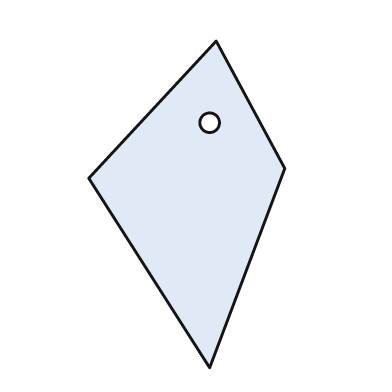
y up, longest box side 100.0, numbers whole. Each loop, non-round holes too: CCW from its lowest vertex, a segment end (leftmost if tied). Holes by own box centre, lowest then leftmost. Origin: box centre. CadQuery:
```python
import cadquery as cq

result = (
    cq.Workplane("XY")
    .moveTo(7.0, -50.0)
    .lineTo(30.0, 11.0)
    .lineTo(9.0, 50.0)
    .lineTo(-30.0, 8.0)
    .close()
    .moveTo(7.0, 25.0)
    .circle(3.0)
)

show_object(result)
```